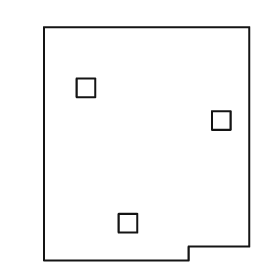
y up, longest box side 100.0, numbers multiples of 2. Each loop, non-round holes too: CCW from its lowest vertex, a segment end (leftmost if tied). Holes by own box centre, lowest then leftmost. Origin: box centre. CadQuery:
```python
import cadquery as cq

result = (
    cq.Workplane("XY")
    .moveTo(-44.0, -50.0)
    .lineTo(18.0, -50.0)
    .lineTo(18.0, -44.0)
    .lineTo(44.0, -44.0)
    .lineTo(44.0, 50.0)
    .lineTo(-44.0, 50.0)
    .close()
    .moveTo(-12.0, -38.0)
    .lineTo(-4.0, -38.0)
    .lineTo(-4.0, -30.0)
    .lineTo(-12.0, -30.0)
    .close()
    .moveTo(28.0, 6.0)
    .lineTo(36.0, 6.0)
    .lineTo(36.0, 14.0)
    .lineTo(28.0, 14.0)
    .close()
    .moveTo(-30.0, 20.0)
    .lineTo(-22.0, 20.0)
    .lineTo(-22.0, 28.0)
    .lineTo(-30.0, 28.0)
    .close()
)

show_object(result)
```